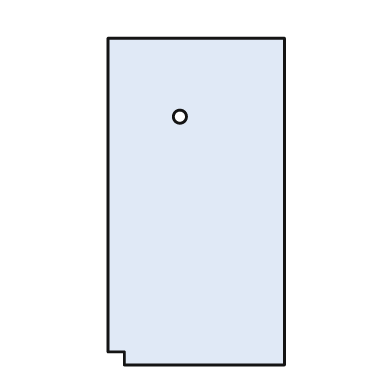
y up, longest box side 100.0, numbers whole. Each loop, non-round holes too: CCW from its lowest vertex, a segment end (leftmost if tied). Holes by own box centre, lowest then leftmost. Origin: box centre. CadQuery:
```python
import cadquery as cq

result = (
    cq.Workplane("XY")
    .moveTo(-22.0, -50.0)
    .lineTo(27.0, -50.0)
    .lineTo(27.0, 50.0)
    .lineTo(-27.0, 50.0)
    .lineTo(-27.0, -46.0)
    .lineTo(-22.0, -46.0)
    .close()
    .moveTo(-5.0, 26.0)
    .circle(2.0)
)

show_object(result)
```